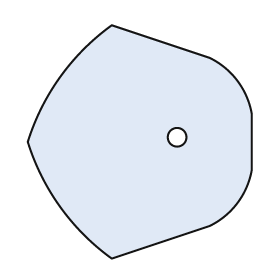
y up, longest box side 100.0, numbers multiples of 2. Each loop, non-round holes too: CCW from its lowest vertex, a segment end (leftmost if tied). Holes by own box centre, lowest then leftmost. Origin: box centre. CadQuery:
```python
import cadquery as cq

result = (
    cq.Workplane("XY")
    .moveTo(-12.0, -50.0)
    .lineTo(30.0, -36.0)
    .threePointArc((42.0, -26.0), (48.0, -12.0))
    .lineTo(48.0, 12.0)
    .threePointArc((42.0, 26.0), (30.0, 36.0))
    .lineTo(-12.0, 50.0)
    .threePointArc((-34.0, 28.0), (-48.0, 0.0))
    .threePointArc((-34.0, -28.0), (-12.0, -50.0))
    .close()
    .moveTo(16.0, 2.0)
    .circle(4.0)
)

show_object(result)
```